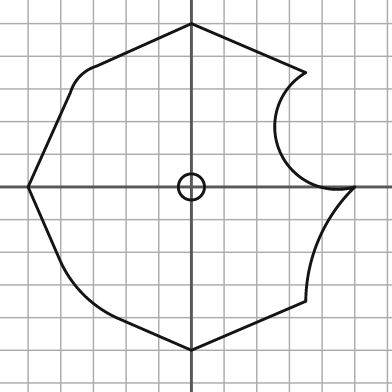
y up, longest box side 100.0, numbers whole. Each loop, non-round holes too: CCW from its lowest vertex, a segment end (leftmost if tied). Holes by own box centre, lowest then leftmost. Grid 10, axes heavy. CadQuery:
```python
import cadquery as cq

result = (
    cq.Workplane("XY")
    .moveTo(0.0, -50.0)
    .lineTo(35.0, -35.0)
    .threePointArc((39.0, -16.0), (50.0, 0.0))
    .threePointArc((27.0, 11.0), (35.0, 35.0))
    .lineTo(0.0, 50.0)
    .lineTo(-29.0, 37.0)
    .threePointArc((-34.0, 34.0), (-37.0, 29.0))
    .lineTo(-50.0, 0.0)
    .lineTo(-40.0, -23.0)
    .threePointArc((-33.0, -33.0), (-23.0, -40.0))
    .close()
    .moveTo(0.0, 0.0)
    .circle(4.0)
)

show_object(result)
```